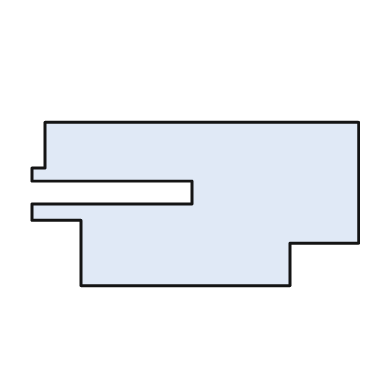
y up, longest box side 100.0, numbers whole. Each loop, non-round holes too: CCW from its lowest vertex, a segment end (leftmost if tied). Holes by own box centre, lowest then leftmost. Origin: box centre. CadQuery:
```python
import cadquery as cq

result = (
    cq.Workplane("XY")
    .moveTo(-35.0, -25.0)
    .lineTo(29.0, -25.0)
    .lineTo(29.0, -12.0)
    .lineTo(50.0, -12.0)
    .lineTo(50.0, 25.0)
    .lineTo(-46.0, 25.0)
    .lineTo(-46.0, 11.0)
    .lineTo(-50.0, 11.0)
    .lineTo(-50.0, 7.0)
    .lineTo(-1.0, 7.0)
    .lineTo(-1.0, 0.0)
    .lineTo(-50.0, 0.0)
    .lineTo(-50.0, -5.0)
    .lineTo(-35.0, -5.0)
    .close()
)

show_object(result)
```